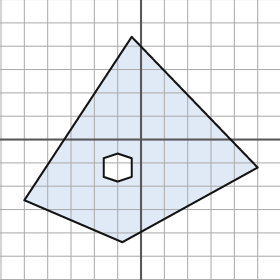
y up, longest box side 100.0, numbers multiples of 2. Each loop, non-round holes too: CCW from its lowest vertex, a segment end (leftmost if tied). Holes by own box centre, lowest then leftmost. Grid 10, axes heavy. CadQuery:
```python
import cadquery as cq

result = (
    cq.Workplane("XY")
    .moveTo(-8.0, -44.0)
    .lineTo(50.0, -12.0)
    .lineTo(-4.0, 44.0)
    .lineTo(-50.0, -26.0)
    .close()
    .moveTo(-10.0, -18.0)
    .lineTo(-4.0, -16.0)
    .lineTo(-4.0, -8.0)
    .lineTo(-10.0, -6.0)
    .lineTo(-16.0, -8.0)
    .lineTo(-16.0, -16.0)
    .close()
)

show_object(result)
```